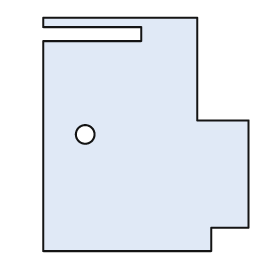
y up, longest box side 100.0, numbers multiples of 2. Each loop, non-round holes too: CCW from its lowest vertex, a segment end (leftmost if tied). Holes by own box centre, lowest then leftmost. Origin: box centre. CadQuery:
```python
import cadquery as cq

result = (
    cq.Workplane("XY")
    .moveTo(-44.0, -50.0)
    .lineTo(28.0, -50.0)
    .lineTo(28.0, -40.0)
    .lineTo(44.0, -40.0)
    .lineTo(44.0, 6.0)
    .lineTo(22.0, 6.0)
    .lineTo(22.0, 50.0)
    .lineTo(-44.0, 50.0)
    .lineTo(-44.0, 46.0)
    .lineTo(-2.0, 46.0)
    .lineTo(-2.0, 40.0)
    .lineTo(-44.0, 40.0)
    .close()
    .moveTo(-26.0, 0.0)
    .circle(4.0)
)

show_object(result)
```